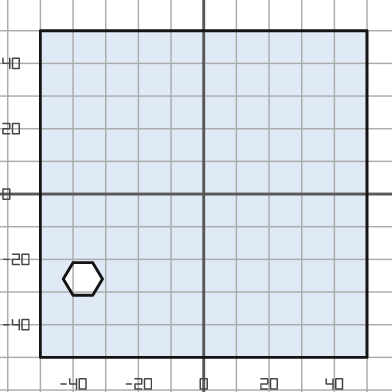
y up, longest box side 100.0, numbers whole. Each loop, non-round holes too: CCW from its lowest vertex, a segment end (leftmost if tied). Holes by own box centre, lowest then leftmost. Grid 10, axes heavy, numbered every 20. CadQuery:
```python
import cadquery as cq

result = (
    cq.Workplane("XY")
    .moveTo(-50.0, -50.0)
    .lineTo(50.0, -50.0)
    .lineTo(50.0, 50.0)
    .lineTo(-50.0, 50.0)
    .close()
    .moveTo(-40.0, -31.0)
    .lineTo(-34.0, -31.0)
    .lineTo(-31.0, -26.0)
    .lineTo(-34.0, -21.0)
    .lineTo(-40.0, -21.0)
    .lineTo(-43.0, -26.0)
    .close()
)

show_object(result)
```